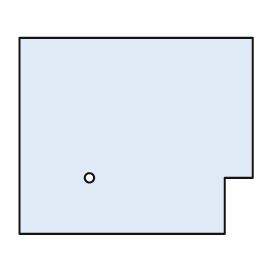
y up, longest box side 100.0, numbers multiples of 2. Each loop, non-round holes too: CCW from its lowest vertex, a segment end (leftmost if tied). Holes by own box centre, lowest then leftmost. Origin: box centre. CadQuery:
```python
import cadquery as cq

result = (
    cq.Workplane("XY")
    .moveTo(-50.0, -42.0)
    .lineTo(38.0, -42.0)
    .lineTo(38.0, -18.0)
    .lineTo(50.0, -18.0)
    .lineTo(50.0, 42.0)
    .lineTo(-50.0, 42.0)
    .close()
    .moveTo(-20.0, -18.0)
    .circle(2.0)
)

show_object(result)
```